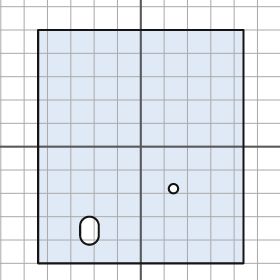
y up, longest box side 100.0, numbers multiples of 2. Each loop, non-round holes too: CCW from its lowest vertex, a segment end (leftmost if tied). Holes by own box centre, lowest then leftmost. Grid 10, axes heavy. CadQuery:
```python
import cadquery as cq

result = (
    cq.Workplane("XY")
    .moveTo(-44.0, -50.0)
    .lineTo(44.0, -50.0)
    .lineTo(44.0, 50.0)
    .lineTo(-44.0, 50.0)
    .close()
    .moveTo(-26.0, -38.0)
    .threePointArc((-22.0, -42.0), (-18.0, -38.0))
    .lineTo(-18.0, -34.0)
    .threePointArc((-22.0, -30.0), (-26.0, -34.0))
    .close()
    .moveTo(14.0, -18.0)
    .circle(2.0)
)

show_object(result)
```